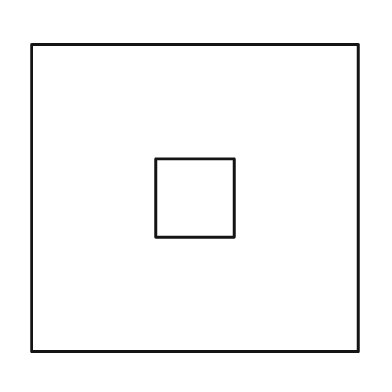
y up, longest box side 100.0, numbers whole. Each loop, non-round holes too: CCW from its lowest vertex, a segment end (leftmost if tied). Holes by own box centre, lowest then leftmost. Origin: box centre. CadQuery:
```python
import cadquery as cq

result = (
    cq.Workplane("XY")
    .moveTo(-50.0, -47.0)
    .lineTo(50.0, -47.0)
    .lineTo(50.0, 47.0)
    .lineTo(-50.0, 47.0)
    .close()
    .moveTo(-12.0, -12.0)
    .lineTo(12.0, -12.0)
    .lineTo(12.0, 12.0)
    .lineTo(-12.0, 12.0)
    .close()
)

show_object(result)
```